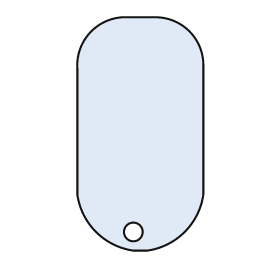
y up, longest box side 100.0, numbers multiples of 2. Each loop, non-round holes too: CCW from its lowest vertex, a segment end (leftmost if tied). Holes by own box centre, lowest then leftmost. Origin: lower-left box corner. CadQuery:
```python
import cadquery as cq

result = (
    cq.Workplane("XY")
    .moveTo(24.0, 0.0)
    .lineTo(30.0, 0.0)
    .threePointArc((46.0, 8.0), (54.0, 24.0))
    .lineTo(54.0, 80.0)
    .threePointArc((48.0, 94.0), (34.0, 100.0))
    .lineTo(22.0, 100.0)
    .threePointArc((6.0, 94.0), (0.0, 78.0))
    .lineTo(0.0, 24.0)
    .threePointArc((8.0, 8.0), (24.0, 0.0))
    .close()
    .moveTo(24.0, 8.0)
    .circle(4.0)
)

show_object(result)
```